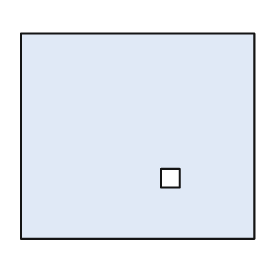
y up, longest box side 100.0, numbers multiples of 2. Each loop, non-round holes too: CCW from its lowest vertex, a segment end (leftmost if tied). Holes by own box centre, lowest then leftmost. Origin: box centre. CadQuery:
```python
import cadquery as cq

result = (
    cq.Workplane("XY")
    .moveTo(-50.0, -44.0)
    .lineTo(50.0, -44.0)
    .lineTo(50.0, 44.0)
    .lineTo(-50.0, 44.0)
    .close()
    .moveTo(10.0, -22.0)
    .lineTo(18.0, -22.0)
    .lineTo(18.0, -14.0)
    .lineTo(10.0, -14.0)
    .close()
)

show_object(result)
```